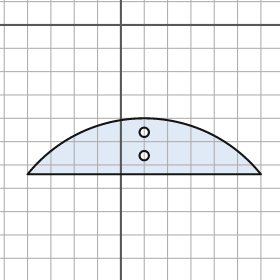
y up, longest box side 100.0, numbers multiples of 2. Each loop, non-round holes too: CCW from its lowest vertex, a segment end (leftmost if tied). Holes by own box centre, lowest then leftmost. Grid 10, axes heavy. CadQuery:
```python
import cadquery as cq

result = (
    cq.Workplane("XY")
    .moveTo(-40.0, -64.0)
    .lineTo(60.0, -64.0)
    .threePointArc((10.0, -40.0), (-40.0, -64.0))
    .close()
    .moveTo(10.0, -56.0)
    .circle(2.0)
    .moveTo(10.0, -46.0)
    .circle(2.0)
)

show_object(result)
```